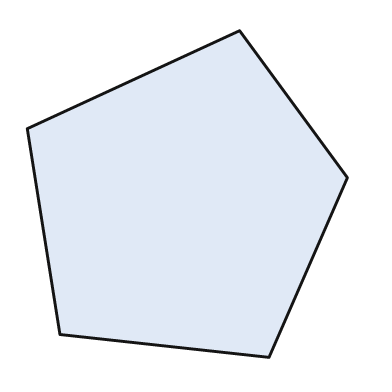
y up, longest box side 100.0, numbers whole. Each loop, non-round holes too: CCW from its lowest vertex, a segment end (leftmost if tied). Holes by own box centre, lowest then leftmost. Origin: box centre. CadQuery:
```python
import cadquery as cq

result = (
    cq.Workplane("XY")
    .moveTo(25.0, -50.0)
    .lineTo(49.0, 5.0)
    .lineTo(16.0, 50.0)
    .lineTo(-49.0, 20.0)
    .lineTo(-39.0, -43.0)
    .close()
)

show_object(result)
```